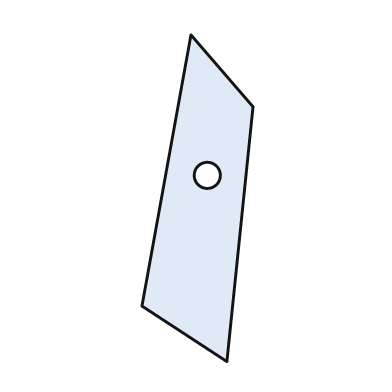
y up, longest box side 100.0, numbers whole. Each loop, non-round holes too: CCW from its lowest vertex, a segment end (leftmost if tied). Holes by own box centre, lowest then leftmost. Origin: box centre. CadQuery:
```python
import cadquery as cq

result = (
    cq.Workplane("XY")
    .moveTo(9.0, -50.0)
    .lineTo(17.0, 28.0)
    .lineTo(-2.0, 50.0)
    .lineTo(-17.0, -33.0)
    .close()
    .moveTo(3.0, 7.0)
    .circle(4.0)
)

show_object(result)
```